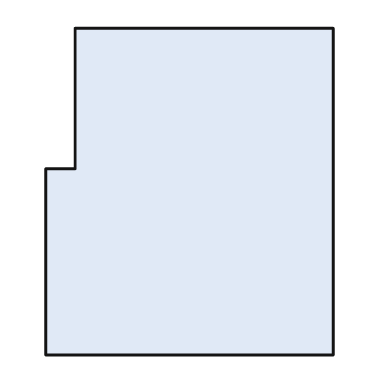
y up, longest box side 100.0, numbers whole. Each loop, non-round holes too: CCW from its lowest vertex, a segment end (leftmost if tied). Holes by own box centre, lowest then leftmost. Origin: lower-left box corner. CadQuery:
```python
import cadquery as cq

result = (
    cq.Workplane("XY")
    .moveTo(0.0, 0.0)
    .lineTo(88.0, 0.0)
    .lineTo(88.0, 100.0)
    .lineTo(9.0, 100.0)
    .lineTo(9.0, 57.0)
    .lineTo(0.0, 57.0)
    .close()
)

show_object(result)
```